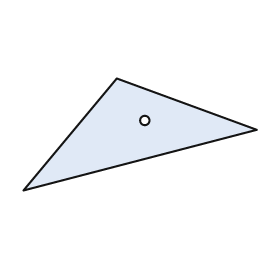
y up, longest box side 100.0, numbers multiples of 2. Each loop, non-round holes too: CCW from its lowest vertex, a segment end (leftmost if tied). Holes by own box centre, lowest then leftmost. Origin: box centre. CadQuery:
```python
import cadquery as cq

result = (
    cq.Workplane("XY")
    .moveTo(-50.0, -24.0)
    .lineTo(50.0, 2.0)
    .lineTo(-10.0, 24.0)
    .close()
    .moveTo(2.0, 6.0)
    .circle(2.0)
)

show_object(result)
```